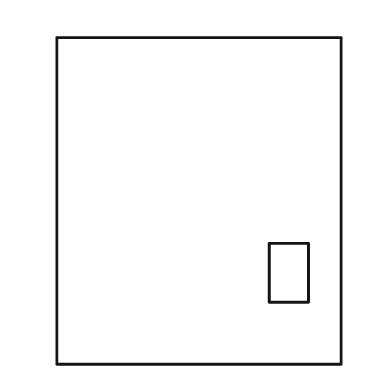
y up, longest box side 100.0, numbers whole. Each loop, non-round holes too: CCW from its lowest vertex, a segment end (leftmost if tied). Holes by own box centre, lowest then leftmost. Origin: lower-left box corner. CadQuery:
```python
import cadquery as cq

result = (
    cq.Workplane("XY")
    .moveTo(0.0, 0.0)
    .lineTo(87.0, 0.0)
    .lineTo(87.0, 100.0)
    .lineTo(0.0, 100.0)
    .close()
    .moveTo(65.0, 19.0)
    .lineTo(77.0, 19.0)
    .lineTo(77.0, 37.0)
    .lineTo(65.0, 37.0)
    .close()
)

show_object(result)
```